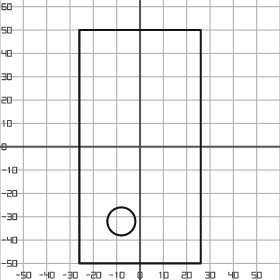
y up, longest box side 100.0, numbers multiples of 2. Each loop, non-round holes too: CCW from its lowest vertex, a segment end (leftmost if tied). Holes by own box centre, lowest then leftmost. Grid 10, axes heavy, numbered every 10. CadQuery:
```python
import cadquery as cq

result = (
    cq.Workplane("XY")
    .moveTo(-26.0, -50.0)
    .lineTo(26.0, -50.0)
    .lineTo(26.0, 50.0)
    .lineTo(-26.0, 50.0)
    .close()
    .moveTo(-8.0, -32.0)
    .circle(6.0)
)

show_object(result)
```